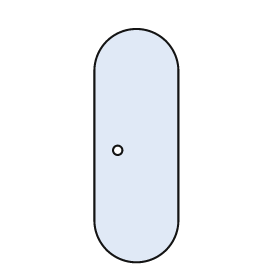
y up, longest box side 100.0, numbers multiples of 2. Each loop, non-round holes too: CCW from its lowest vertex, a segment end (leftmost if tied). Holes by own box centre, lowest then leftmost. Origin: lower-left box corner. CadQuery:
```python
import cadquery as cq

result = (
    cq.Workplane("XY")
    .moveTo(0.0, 18.0)
    .threePointArc((18.0, 0.0), (36.0, 18.0))
    .lineTo(36.0, 82.0)
    .threePointArc((18.0, 100.0), (0.0, 82.0))
    .close()
    .moveTo(10.0, 48.0)
    .circle(2.0)
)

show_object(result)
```